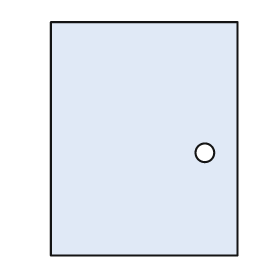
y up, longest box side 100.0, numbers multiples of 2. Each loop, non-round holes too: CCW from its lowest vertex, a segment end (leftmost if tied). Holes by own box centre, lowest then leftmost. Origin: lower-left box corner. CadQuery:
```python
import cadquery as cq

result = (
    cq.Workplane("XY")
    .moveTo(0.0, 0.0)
    .lineTo(80.0, 0.0)
    .lineTo(80.0, 100.0)
    .lineTo(0.0, 100.0)
    .close()
    .moveTo(66.0, 44.0)
    .circle(4.0)
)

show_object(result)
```